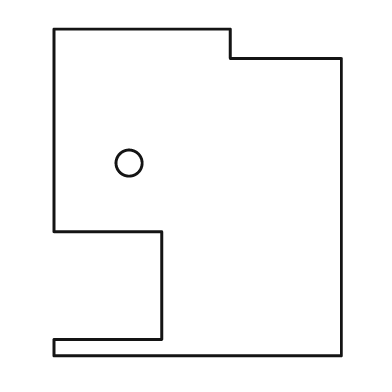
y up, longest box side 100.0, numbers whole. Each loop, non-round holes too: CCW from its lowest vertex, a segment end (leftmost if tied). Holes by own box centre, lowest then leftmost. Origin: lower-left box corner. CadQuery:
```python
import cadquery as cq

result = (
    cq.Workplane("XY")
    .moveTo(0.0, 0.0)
    .lineTo(88.0, 0.0)
    .lineTo(88.0, 91.0)
    .lineTo(54.0, 91.0)
    .lineTo(54.0, 100.0)
    .lineTo(0.0, 100.0)
    .lineTo(0.0, 38.0)
    .lineTo(33.0, 38.0)
    .lineTo(33.0, 5.0)
    .lineTo(0.0, 5.0)
    .close()
    .moveTo(23.0, 59.0)
    .circle(4.0)
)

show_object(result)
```